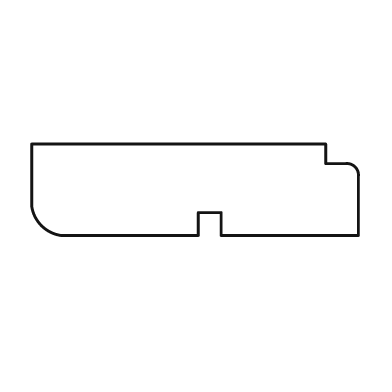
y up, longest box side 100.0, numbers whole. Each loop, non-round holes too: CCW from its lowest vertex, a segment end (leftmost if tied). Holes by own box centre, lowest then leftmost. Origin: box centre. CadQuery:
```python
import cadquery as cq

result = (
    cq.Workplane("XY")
    .moveTo(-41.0, -14.0)
    .lineTo(1.0, -14.0)
    .lineTo(1.0, -7.0)
    .lineTo(8.0, -7.0)
    .lineTo(8.0, -14.0)
    .lineTo(50.0, -14.0)
    .lineTo(50.0, 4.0)
    .threePointArc((49.0, 7.0), (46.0, 8.0))
    .lineTo(40.0, 8.0)
    .lineTo(40.0, 14.0)
    .lineTo(-50.0, 14.0)
    .lineTo(-50.0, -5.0)
    .threePointArc((-47.0, -11.0), (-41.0, -14.0))
    .close()
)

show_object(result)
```